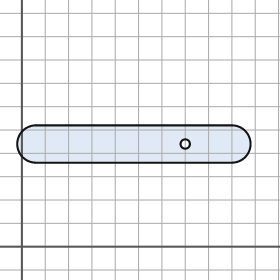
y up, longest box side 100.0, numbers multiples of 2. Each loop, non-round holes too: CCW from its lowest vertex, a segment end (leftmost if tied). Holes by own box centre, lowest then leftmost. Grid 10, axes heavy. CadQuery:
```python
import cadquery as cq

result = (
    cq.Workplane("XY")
    .moveTo(6.0, 36.0)
    .lineTo(90.0, 36.0)
    .threePointArc((98.0, 44.0), (90.0, 52.0))
    .lineTo(6.0, 52.0)
    .threePointArc((-2.0, 44.0), (6.0, 36.0))
    .close()
    .moveTo(70.0, 44.0)
    .circle(2.0)
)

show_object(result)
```